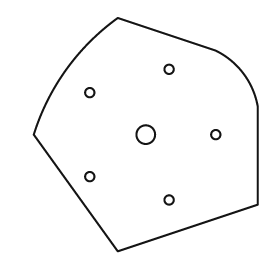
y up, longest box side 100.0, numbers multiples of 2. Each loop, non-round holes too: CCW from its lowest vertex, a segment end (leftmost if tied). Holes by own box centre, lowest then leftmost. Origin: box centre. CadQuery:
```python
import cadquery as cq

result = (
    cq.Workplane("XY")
    .moveTo(-12.0, -50.0)
    .lineTo(48.0, -30.0)
    .lineTo(48.0, 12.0)
    .threePointArc((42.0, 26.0), (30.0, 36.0))
    .lineTo(-12.0, 50.0)
    .threePointArc((-34.0, 28.0), (-48.0, 0.0))
    .close()
    .moveTo(10.0, -28.0)
    .circle(2.0)
    .moveTo(-24.0, -18.0)
    .circle(2.0)
    .moveTo(0.0, 0.0)
    .circle(4.0)
    .moveTo(30.0, 0.0)
    .circle(2.0)
    .moveTo(-24.0, 18.0)
    .circle(2.0)
    .moveTo(10.0, 28.0)
    .circle(2.0)
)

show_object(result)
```